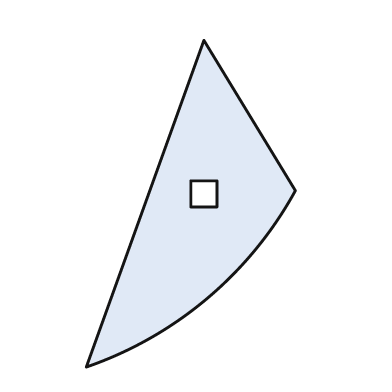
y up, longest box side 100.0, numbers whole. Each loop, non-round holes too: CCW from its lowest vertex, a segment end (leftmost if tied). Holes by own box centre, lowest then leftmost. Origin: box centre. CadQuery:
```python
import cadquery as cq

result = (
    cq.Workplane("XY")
    .moveTo(-32.0, -50.0)
    .threePointArc((5.0, -29.0), (32.0, 4.0))
    .lineTo(4.0, 50.0)
    .close()
    .moveTo(0.0, -1.0)
    .lineTo(8.0, -1.0)
    .lineTo(8.0, 7.0)
    .lineTo(0.0, 7.0)
    .close()
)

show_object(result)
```